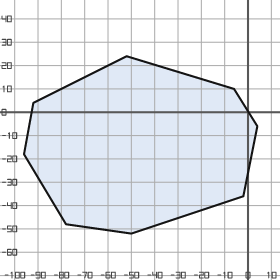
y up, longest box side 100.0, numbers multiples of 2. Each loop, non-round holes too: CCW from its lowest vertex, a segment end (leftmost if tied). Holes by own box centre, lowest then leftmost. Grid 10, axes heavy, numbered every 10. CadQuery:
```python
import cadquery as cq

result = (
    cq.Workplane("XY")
    .moveTo(-50.0, -52.0)
    .lineTo(-2.0, -36.0)
    .lineTo(4.0, -6.0)
    .lineTo(-6.0, 10.0)
    .lineTo(-52.0, 24.0)
    .lineTo(-92.0, 4.0)
    .lineTo(-96.0, -18.0)
    .lineTo(-78.0, -48.0)
    .close()
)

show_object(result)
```